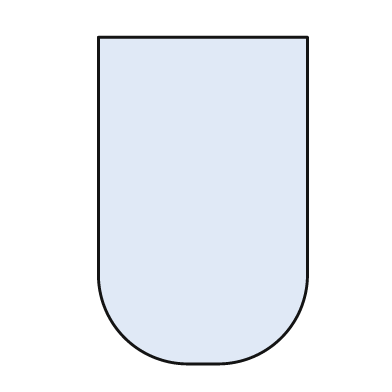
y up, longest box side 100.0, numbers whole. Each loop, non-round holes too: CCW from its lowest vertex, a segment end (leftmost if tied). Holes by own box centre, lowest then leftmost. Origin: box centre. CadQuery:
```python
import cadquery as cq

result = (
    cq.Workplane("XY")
    .moveTo(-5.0, -50.0)
    .lineTo(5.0, -50.0)
    .threePointArc((24.0, -42.0), (32.0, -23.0))
    .lineTo(32.0, 50.0)
    .lineTo(-32.0, 50.0)
    .lineTo(-32.0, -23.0)
    .threePointArc((-24.0, -42.0), (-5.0, -50.0))
    .close()
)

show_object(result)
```